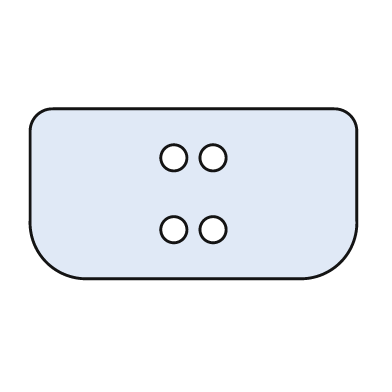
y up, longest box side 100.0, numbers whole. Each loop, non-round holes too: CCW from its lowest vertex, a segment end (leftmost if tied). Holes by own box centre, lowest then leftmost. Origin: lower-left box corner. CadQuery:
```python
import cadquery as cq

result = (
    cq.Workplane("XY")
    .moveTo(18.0, 0.0)
    .lineTo(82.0, 0.0)
    .threePointArc((95.0, 5.0), (100.0, 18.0))
    .lineTo(100.0, 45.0)
    .threePointArc((98.0, 50.0), (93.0, 52.0))
    .lineTo(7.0, 52.0)
    .threePointArc((2.0, 50.0), (0.0, 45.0))
    .lineTo(0.0, 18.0)
    .threePointArc((5.0, 5.0), (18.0, 0.0))
    .close()
    .moveTo(44.0, 15.0)
    .circle(4.0)
    .moveTo(56.0, 15.0)
    .circle(4.0)
    .moveTo(44.0, 37.0)
    .circle(4.0)
    .moveTo(56.0, 37.0)
    .circle(4.0)
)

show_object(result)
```